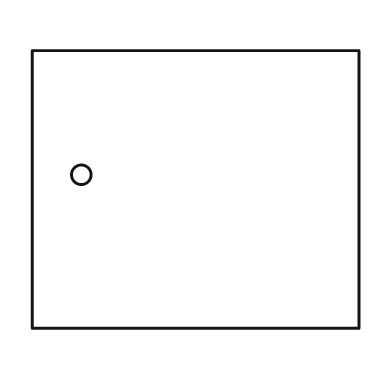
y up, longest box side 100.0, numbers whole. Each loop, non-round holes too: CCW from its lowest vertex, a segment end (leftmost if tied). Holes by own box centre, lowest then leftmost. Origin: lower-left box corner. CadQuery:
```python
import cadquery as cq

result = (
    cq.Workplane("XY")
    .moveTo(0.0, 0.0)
    .lineTo(100.0, 0.0)
    .lineTo(100.0, 85.0)
    .lineTo(0.0, 85.0)
    .close()
    .moveTo(15.0, 47.0)
    .circle(3.0)
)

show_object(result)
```